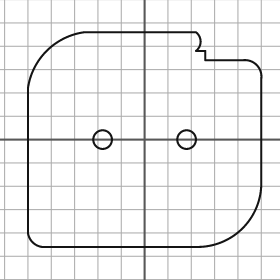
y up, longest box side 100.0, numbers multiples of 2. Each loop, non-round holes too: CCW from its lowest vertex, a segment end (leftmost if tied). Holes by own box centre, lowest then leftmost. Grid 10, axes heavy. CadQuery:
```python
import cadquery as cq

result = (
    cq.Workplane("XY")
    .moveTo(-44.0, -46.0)
    .lineTo(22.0, -46.0)
    .threePointArc((42.0, -38.0), (50.0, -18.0))
    .lineTo(50.0, 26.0)
    .threePointArc((48.0, 32.0), (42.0, 34.0))
    .lineTo(26.0, 34.0)
    .lineTo(26.0, 38.0)
    .lineTo(22.0, 38.0)
    .threePointArc((24.0, 42.0), (22.0, 46.0))
    .lineTo(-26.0, 46.0)
    .threePointArc((-42.0, 38.0), (-50.0, 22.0))
    .lineTo(-50.0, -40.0)
    .threePointArc((-48.0, -44.0), (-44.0, -46.0))
    .close()
    .moveTo(-18.0, 0.0)
    .circle(4.0)
    .moveTo(18.0, 0.0)
    .circle(4.0)
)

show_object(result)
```